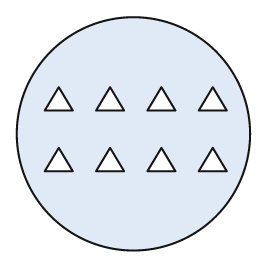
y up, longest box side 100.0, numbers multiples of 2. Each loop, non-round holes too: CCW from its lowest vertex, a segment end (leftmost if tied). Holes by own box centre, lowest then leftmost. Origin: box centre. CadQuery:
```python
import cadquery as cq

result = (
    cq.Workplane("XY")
    .moveTo(0.0, 0.0)
    .circle(50.0)
    .moveTo(-38.0, -16.0)
    .lineTo(-26.0, -16.0)
    .lineTo(-32.0, -6.0)
    .close()
    .moveTo(-16.0, -16.0)
    .lineTo(-4.0, -16.0)
    .lineTo(-10.0, -6.0)
    .close()
    .moveTo(6.0, -16.0)
    .lineTo(18.0, -16.0)
    .lineTo(12.0, -6.0)
    .close()
    .moveTo(28.0, -16.0)
    .lineTo(40.0, -16.0)
    .lineTo(34.0, -6.0)
    .close()
    .moveTo(-38.0, 10.0)
    .lineTo(-26.0, 10.0)
    .lineTo(-32.0, 20.0)
    .close()
    .moveTo(-16.0, 10.0)
    .lineTo(-4.0, 10.0)
    .lineTo(-10.0, 20.0)
    .close()
    .moveTo(6.0, 10.0)
    .lineTo(18.0, 10.0)
    .lineTo(12.0, 20.0)
    .close()
    .moveTo(28.0, 10.0)
    .lineTo(40.0, 10.0)
    .lineTo(34.0, 20.0)
    .close()
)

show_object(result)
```